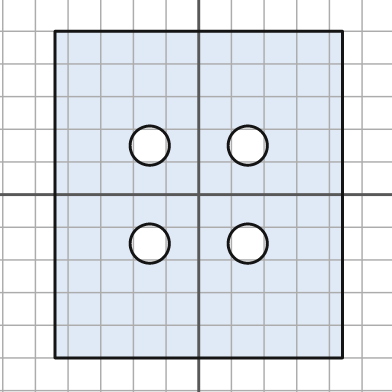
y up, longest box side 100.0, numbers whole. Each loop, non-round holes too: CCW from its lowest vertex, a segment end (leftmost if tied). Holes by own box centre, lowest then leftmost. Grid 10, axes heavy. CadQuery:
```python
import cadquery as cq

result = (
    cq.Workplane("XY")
    .moveTo(-44.0, -50.0)
    .lineTo(44.0, -50.0)
    .lineTo(44.0, 50.0)
    .lineTo(-44.0, 50.0)
    .close()
    .moveTo(-15.0, -15.0)
    .circle(6.0)
    .moveTo(15.0, -15.0)
    .circle(6.0)
    .moveTo(-15.0, 15.0)
    .circle(6.0)
    .moveTo(15.0, 15.0)
    .circle(6.0)
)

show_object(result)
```